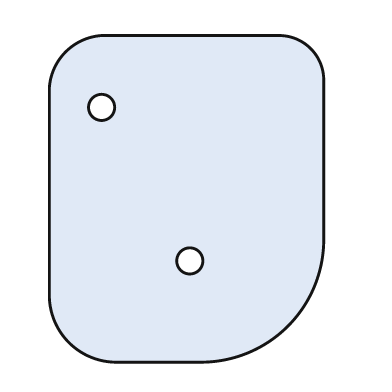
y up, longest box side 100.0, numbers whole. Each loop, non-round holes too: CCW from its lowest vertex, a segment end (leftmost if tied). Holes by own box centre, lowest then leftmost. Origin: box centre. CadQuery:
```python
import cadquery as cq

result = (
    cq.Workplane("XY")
    .moveTo(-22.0, -50.0)
    .lineTo(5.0, -50.0)
    .threePointArc((31.0, -39.0), (42.0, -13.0))
    .lineTo(42.0, 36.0)
    .threePointArc((38.0, 46.0), (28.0, 50.0))
    .lineTo(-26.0, 50.0)
    .threePointArc((-37.0, 45.0), (-42.0, 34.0))
    .lineTo(-42.0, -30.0)
    .threePointArc((-36.0, -44.0), (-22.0, -50.0))
    .close()
    .moveTo(1.0, -19.0)
    .circle(4.0)
    .moveTo(-26.0, 28.0)
    .circle(4.0)
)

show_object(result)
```